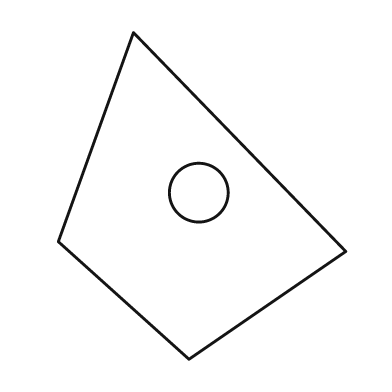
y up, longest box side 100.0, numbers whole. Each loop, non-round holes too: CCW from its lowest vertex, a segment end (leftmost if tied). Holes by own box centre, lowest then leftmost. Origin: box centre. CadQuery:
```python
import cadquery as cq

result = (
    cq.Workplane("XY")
    .moveTo(-4.0, -50.0)
    .lineTo(44.0, -17.0)
    .lineTo(-21.0, 50.0)
    .lineTo(-44.0, -14.0)
    .close()
    .moveTo(-1.0, 1.0)
    .circle(9.0)
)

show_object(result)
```